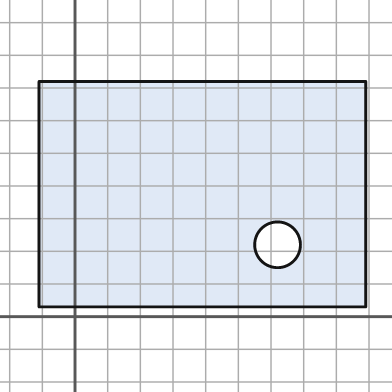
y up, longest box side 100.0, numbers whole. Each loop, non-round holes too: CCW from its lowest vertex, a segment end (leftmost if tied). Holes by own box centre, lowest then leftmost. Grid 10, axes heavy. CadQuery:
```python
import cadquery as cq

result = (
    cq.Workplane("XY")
    .moveTo(-11.0, 3.0)
    .lineTo(89.0, 3.0)
    .lineTo(89.0, 72.0)
    .lineTo(-11.0, 72.0)
    .close()
    .moveTo(62.0, 22.0)
    .circle(7.0)
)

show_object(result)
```